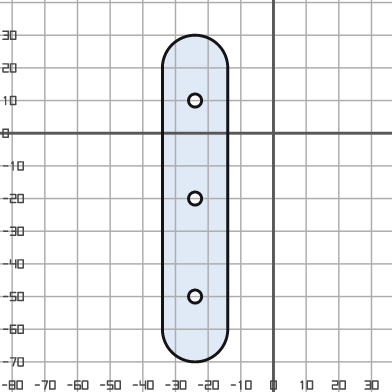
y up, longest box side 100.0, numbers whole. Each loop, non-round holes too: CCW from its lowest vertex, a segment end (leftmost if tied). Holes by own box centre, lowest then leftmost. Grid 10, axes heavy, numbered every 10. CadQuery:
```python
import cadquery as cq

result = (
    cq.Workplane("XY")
    .moveTo(-34.0, -60.0)
    .threePointArc((-24.0, -70.0), (-14.0, -60.0))
    .lineTo(-14.0, 20.0)
    .threePointArc((-24.0, 30.0), (-34.0, 20.0))
    .close()
    .moveTo(-24.0, -50.0)
    .circle(2.0)
    .moveTo(-24.0, -20.0)
    .circle(2.0)
    .moveTo(-24.0, 10.0)
    .circle(2.0)
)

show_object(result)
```